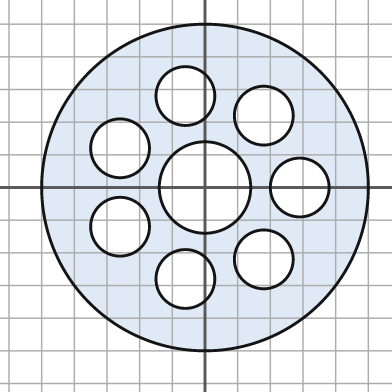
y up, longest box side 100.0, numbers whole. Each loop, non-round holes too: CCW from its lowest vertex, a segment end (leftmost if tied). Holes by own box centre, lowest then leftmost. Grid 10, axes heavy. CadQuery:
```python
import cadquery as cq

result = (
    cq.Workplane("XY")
    .moveTo(0.0, 0.0)
    .circle(50.0)
    .moveTo(-6.0, -28.0)
    .circle(9.0)
    .moveTo(18.0, -22.0)
    .circle(9.0)
    .moveTo(-26.0, -12.0)
    .circle(9.0)
    .moveTo(0.0, 0.0)
    .circle(14.0)
    .moveTo(29.0, 0.0)
    .circle(9.0)
    .moveTo(-26.0, 12.0)
    .circle(9.0)
    .moveTo(18.0, 22.0)
    .circle(9.0)
    .moveTo(-6.0, 28.0)
    .circle(9.0)
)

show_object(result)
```